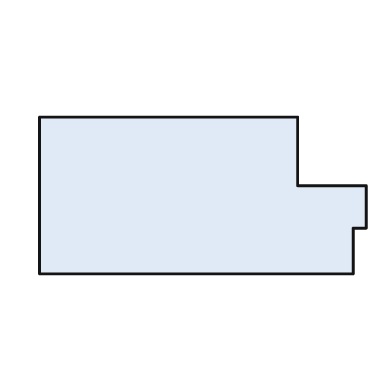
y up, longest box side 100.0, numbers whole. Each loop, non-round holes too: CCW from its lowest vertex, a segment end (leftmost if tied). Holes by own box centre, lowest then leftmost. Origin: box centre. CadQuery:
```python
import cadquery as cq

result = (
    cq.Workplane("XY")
    .moveTo(-50.0, -24.0)
    .lineTo(46.0, -24.0)
    .lineTo(46.0, -10.0)
    .lineTo(50.0, -10.0)
    .lineTo(50.0, 3.0)
    .lineTo(29.0, 3.0)
    .lineTo(29.0, 24.0)
    .lineTo(-50.0, 24.0)
    .close()
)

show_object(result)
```